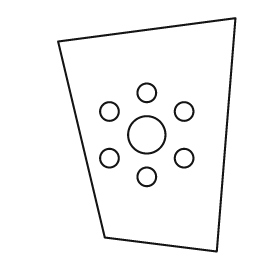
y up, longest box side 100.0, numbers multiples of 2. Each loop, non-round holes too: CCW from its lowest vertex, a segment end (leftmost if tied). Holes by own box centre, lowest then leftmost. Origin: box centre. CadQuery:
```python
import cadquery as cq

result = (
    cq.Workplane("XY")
    .moveTo(30.0, -50.0)
    .lineTo(38.0, 50.0)
    .lineTo(-38.0, 40.0)
    .lineTo(-18.0, -44.0)
    .close()
    .moveTo(0.0, -18.0)
    .circle(4.0)
    .moveTo(-16.0, -10.0)
    .circle(4.0)
    .moveTo(16.0, -10.0)
    .circle(4.0)
    .moveTo(0.0, 0.0)
    .circle(8.0)
    .moveTo(-16.0, 10.0)
    .circle(4.0)
    .moveTo(16.0, 10.0)
    .circle(4.0)
    .moveTo(0.0, 18.0)
    .circle(4.0)
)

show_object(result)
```